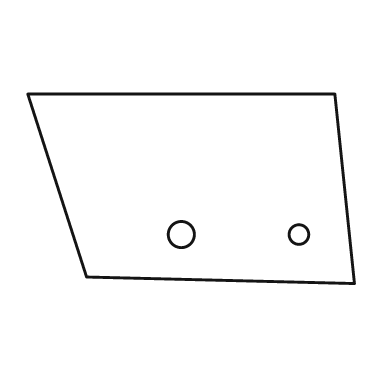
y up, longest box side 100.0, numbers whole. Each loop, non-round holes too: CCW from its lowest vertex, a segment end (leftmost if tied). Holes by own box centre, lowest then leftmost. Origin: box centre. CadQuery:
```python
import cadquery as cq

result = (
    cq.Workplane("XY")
    .moveTo(50.0, -29.0)
    .lineTo(44.0, 29.0)
    .lineTo(-50.0, 29.0)
    .lineTo(-32.0, -27.0)
    .close()
    .moveTo(-3.0, -14.0)
    .circle(4.0)
    .moveTo(33.0, -14.0)
    .circle(3.0)
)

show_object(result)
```